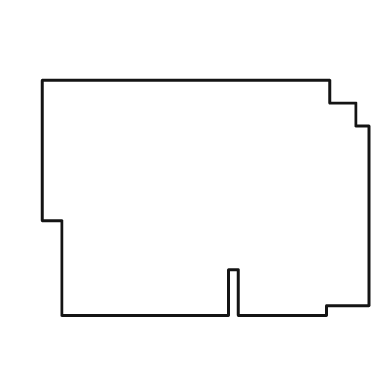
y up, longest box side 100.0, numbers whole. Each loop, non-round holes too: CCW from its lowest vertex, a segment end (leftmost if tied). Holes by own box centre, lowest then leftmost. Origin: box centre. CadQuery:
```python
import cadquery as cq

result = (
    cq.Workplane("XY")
    .moveTo(-44.0, -36.0)
    .lineTo(7.0, -36.0)
    .lineTo(7.0, -22.0)
    .lineTo(10.0, -22.0)
    .lineTo(10.0, -36.0)
    .lineTo(37.0, -36.0)
    .lineTo(37.0, -33.0)
    .lineTo(50.0, -33.0)
    .lineTo(50.0, 22.0)
    .lineTo(46.0, 22.0)
    .lineTo(46.0, 29.0)
    .lineTo(38.0, 29.0)
    .lineTo(38.0, 36.0)
    .lineTo(-50.0, 36.0)
    .lineTo(-50.0, -7.0)
    .lineTo(-44.0, -7.0)
    .close()
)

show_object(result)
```